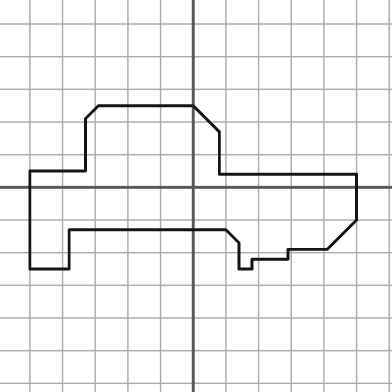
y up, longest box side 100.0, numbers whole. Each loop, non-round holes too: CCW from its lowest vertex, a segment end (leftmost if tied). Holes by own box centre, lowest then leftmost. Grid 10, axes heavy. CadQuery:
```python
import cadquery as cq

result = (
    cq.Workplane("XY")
    .moveTo(-50.0, -25.0)
    .lineTo(-38.0, -25.0)
    .lineTo(-38.0, -13.0)
    .lineTo(10.0, -13.0)
    .lineTo(14.0, -17.0)
    .lineTo(14.0, -25.0)
    .lineTo(18.0, -25.0)
    .lineTo(18.0, -22.0)
    .lineTo(29.0, -22.0)
    .lineTo(29.0, -19.0)
    .lineTo(41.0, -19.0)
    .lineTo(50.0, -10.0)
    .lineTo(50.0, 4.0)
    .lineTo(8.0, 4.0)
    .lineTo(8.0, 17.0)
    .lineTo(0.0, 25.0)
    .lineTo(-29.0, 25.0)
    .lineTo(-33.0, 21.0)
    .lineTo(-33.0, 5.0)
    .lineTo(-50.0, 5.0)
    .close()
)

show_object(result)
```